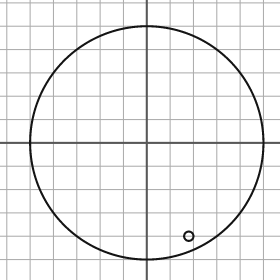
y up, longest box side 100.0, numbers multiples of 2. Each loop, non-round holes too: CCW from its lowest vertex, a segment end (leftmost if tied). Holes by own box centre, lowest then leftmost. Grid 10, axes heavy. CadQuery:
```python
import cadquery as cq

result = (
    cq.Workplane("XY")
    .moveTo(0.0, 0.0)
    .circle(50.0)
    .moveTo(18.0, -40.0)
    .circle(2.0)
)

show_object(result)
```